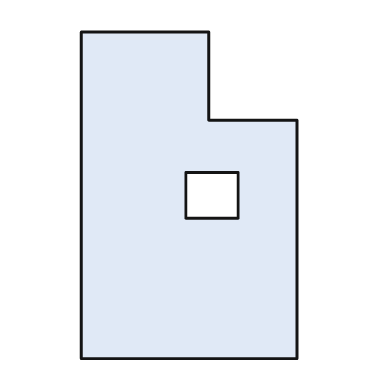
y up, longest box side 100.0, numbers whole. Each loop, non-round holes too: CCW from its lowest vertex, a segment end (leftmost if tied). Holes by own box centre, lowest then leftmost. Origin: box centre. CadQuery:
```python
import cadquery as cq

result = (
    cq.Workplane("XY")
    .moveTo(-33.0, -50.0)
    .lineTo(33.0, -50.0)
    .lineTo(33.0, 23.0)
    .lineTo(6.0, 23.0)
    .lineTo(6.0, 50.0)
    .lineTo(-33.0, 50.0)
    .close()
    .moveTo(-1.0, -7.0)
    .lineTo(15.0, -7.0)
    .lineTo(15.0, 7.0)
    .lineTo(-1.0, 7.0)
    .close()
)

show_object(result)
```